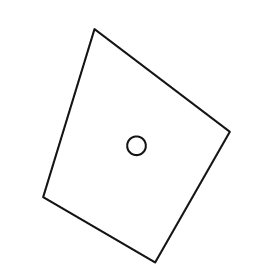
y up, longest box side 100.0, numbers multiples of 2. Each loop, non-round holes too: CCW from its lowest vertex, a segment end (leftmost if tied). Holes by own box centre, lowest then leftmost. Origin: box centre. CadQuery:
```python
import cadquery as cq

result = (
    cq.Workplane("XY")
    .moveTo(8.0, -50.0)
    .lineTo(40.0, 6.0)
    .lineTo(-18.0, 50.0)
    .lineTo(-40.0, -22.0)
    .close()
    .moveTo(0.0, 0.0)
    .circle(4.0)
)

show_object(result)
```